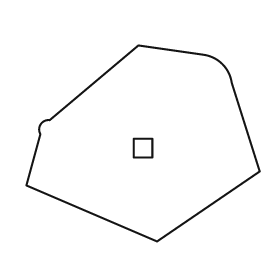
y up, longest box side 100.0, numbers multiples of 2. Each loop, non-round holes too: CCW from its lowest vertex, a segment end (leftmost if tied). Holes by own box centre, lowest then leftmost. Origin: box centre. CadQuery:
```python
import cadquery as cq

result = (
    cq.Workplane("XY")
    .moveTo(6.0, -42.0)
    .lineTo(50.0, -12.0)
    .lineTo(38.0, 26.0)
    .threePointArc((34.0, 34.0), (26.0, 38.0))
    .lineTo(-2.0, 42.0)
    .lineTo(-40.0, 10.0)
    .threePointArc((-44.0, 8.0), (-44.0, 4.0))
    .lineTo(-50.0, -18.0)
    .close()
    .moveTo(-4.0, -6.0)
    .lineTo(4.0, -6.0)
    .lineTo(4.0, 2.0)
    .lineTo(-4.0, 2.0)
    .close()
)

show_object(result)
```